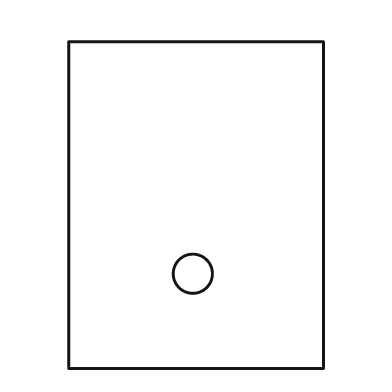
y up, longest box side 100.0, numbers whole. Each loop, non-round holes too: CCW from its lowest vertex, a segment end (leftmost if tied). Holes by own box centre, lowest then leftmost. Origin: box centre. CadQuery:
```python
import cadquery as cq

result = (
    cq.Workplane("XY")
    .moveTo(-39.0, -50.0)
    .lineTo(39.0, -50.0)
    .lineTo(39.0, 50.0)
    .lineTo(-39.0, 50.0)
    .close()
    .moveTo(-1.0, -21.0)
    .circle(6.0)
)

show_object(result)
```